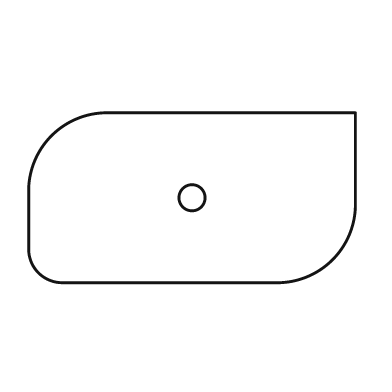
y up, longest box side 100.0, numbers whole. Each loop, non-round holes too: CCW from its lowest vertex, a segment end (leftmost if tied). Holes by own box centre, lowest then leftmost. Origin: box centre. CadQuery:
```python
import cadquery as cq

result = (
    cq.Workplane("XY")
    .moveTo(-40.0, -26.0)
    .lineTo(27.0, -26.0)
    .threePointArc((43.0, -19.0), (50.0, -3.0))
    .lineTo(50.0, 26.0)
    .lineTo(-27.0, 26.0)
    .threePointArc((-43.0, 19.0), (-50.0, 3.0))
    .lineTo(-50.0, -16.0)
    .threePointArc((-47.0, -23.0), (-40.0, -26.0))
    .close()
    .moveTo(0.0, 0.0)
    .circle(4.0)
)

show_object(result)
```